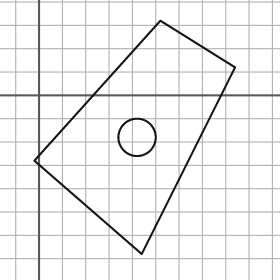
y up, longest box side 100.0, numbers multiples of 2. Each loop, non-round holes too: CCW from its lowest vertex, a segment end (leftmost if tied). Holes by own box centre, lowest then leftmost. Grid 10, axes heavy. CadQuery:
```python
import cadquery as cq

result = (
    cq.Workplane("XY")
    .moveTo(44.0, -68.0)
    .lineTo(84.0, 12.0)
    .lineTo(52.0, 32.0)
    .lineTo(-2.0, -28.0)
    .close()
    .moveTo(42.0, -18.0)
    .circle(8.0)
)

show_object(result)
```